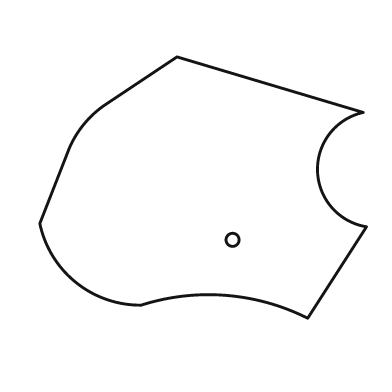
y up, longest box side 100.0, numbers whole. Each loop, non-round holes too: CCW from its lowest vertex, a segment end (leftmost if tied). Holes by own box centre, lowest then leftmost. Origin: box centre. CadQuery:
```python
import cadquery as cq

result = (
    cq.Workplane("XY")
    .moveTo(32.0, -40.0)
    .lineTo(50.0, -12.0)
    .threePointArc((35.0, 5.0), (49.0, 23.0))
    .lineTo(-8.0, 40.0)
    .lineTo(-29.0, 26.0)
    .threePointArc((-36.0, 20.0), (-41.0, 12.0))
    .lineTo(-50.0, -11.0)
    .threePointArc((-39.0, -29.0), (-19.0, -36.0))
    .threePointArc((7.0, -33.0), (32.0, -40.0))
    .close()
    .moveTo(9.0, -16.0)
    .circle(2.0)
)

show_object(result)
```